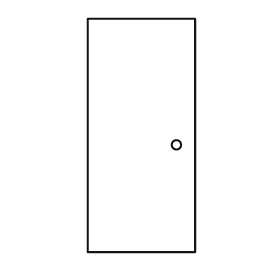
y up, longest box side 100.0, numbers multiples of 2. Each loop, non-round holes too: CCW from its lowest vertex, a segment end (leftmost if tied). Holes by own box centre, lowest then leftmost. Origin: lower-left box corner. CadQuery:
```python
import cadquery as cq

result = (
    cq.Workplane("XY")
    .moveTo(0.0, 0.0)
    .lineTo(46.0, 0.0)
    .lineTo(46.0, 100.0)
    .lineTo(0.0, 100.0)
    .close()
    .moveTo(38.0, 46.0)
    .circle(2.0)
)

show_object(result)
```